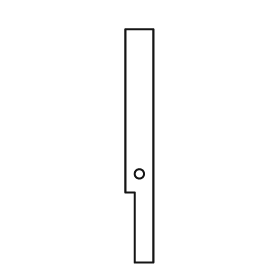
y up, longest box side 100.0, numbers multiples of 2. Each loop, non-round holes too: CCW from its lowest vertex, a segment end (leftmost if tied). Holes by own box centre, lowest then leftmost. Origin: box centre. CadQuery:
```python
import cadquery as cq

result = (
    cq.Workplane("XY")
    .moveTo(-2.0, -50.0)
    .lineTo(6.0, -50.0)
    .lineTo(6.0, 50.0)
    .lineTo(-6.0, 50.0)
    .lineTo(-6.0, -20.0)
    .lineTo(-2.0, -20.0)
    .close()
    .moveTo(0.0, -12.0)
    .circle(2.0)
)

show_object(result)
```